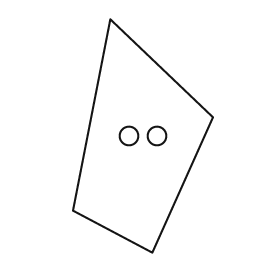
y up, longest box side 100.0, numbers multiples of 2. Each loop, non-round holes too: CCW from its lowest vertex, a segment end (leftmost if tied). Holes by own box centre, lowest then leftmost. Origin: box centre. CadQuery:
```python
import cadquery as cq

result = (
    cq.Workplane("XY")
    .moveTo(4.0, -50.0)
    .lineTo(30.0, 8.0)
    .lineTo(-14.0, 50.0)
    .lineTo(-30.0, -32.0)
    .close()
    .moveTo(-6.0, 0.0)
    .circle(4.0)
    .moveTo(6.0, 0.0)
    .circle(4.0)
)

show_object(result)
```